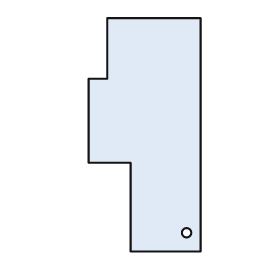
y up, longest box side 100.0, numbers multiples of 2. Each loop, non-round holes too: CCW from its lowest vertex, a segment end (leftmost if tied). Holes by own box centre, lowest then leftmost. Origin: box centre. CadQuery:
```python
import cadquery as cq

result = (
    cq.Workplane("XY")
    .moveTo(-6.0, -50.0)
    .lineTo(24.0, -50.0)
    .lineTo(24.0, 50.0)
    .lineTo(-16.0, 50.0)
    .lineTo(-16.0, 24.0)
    .lineTo(-24.0, 24.0)
    .lineTo(-24.0, -12.0)
    .lineTo(-6.0, -12.0)
    .close()
    .moveTo(18.0, -42.0)
    .circle(2.0)
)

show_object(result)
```